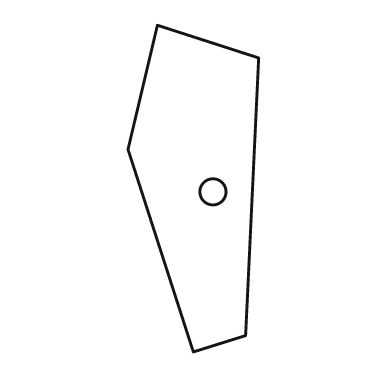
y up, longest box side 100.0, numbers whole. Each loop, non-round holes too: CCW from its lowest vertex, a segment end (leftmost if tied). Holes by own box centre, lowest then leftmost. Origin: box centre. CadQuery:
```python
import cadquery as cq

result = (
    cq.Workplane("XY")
    .moveTo(0.0, -50.0)
    .lineTo(16.0, -45.0)
    .lineTo(20.0, 40.0)
    .lineTo(-11.0, 50.0)
    .lineTo(-20.0, 12.0)
    .close()
    .moveTo(6.0, -1.0)
    .circle(4.0)
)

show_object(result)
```